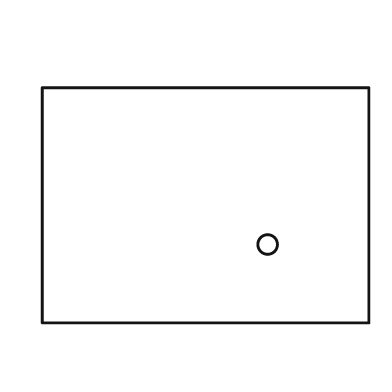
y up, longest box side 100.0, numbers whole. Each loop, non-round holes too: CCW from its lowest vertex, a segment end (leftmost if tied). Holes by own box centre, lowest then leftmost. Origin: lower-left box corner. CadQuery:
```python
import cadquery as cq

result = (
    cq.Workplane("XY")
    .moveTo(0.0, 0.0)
    .lineTo(100.0, 0.0)
    .lineTo(100.0, 72.0)
    .lineTo(0.0, 72.0)
    .close()
    .moveTo(69.0, 24.0)
    .circle(3.0)
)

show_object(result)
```